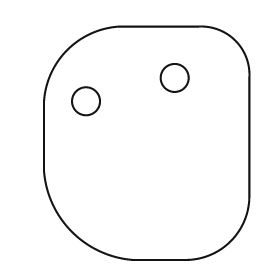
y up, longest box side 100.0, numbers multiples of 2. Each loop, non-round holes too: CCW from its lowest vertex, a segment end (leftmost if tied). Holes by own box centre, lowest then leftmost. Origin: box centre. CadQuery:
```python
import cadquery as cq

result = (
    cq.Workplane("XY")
    .moveTo(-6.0, -50.0)
    .lineTo(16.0, -50.0)
    .threePointArc((36.0, -42.0), (44.0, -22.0))
    .lineTo(44.0, 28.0)
    .threePointArc((38.0, 44.0), (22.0, 50.0))
    .lineTo(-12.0, 50.0)
    .threePointArc((-34.0, 40.0), (-44.0, 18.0))
    .lineTo(-44.0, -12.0)
    .threePointArc((-32.0, -38.0), (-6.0, -50.0))
    .close()
    .moveTo(-26.0, 18.0)
    .circle(6.0)
    .moveTo(12.0, 28.0)
    .circle(6.0)
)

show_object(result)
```